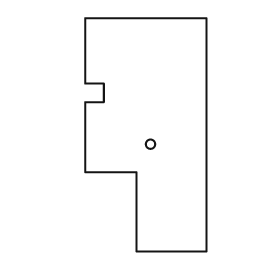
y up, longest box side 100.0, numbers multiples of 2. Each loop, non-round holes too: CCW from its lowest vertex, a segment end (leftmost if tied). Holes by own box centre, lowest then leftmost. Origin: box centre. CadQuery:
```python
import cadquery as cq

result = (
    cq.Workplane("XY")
    .moveTo(-4.0, -50.0)
    .lineTo(26.0, -50.0)
    .lineTo(26.0, 50.0)
    .lineTo(-26.0, 50.0)
    .lineTo(-26.0, 22.0)
    .lineTo(-18.0, 22.0)
    .lineTo(-18.0, 14.0)
    .lineTo(-26.0, 14.0)
    .lineTo(-26.0, -16.0)
    .lineTo(-4.0, -16.0)
    .close()
    .moveTo(2.0, -4.0)
    .circle(2.0)
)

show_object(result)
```